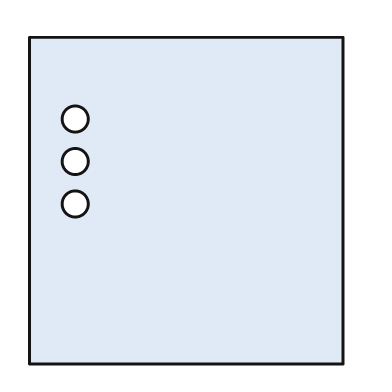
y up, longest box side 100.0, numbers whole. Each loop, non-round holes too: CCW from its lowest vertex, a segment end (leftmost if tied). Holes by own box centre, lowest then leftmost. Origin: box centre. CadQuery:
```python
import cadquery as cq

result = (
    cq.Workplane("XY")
    .moveTo(-48.0, -50.0)
    .lineTo(48.0, -50.0)
    .lineTo(48.0, 50.0)
    .lineTo(-48.0, 50.0)
    .close()
    .moveTo(-34.0, -1.0)
    .circle(4.0)
    .moveTo(-34.0, 12.0)
    .circle(4.0)
    .moveTo(-34.0, 25.0)
    .circle(4.0)
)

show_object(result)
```